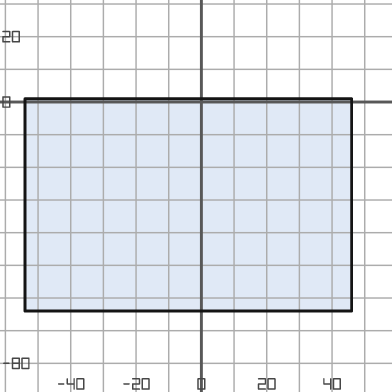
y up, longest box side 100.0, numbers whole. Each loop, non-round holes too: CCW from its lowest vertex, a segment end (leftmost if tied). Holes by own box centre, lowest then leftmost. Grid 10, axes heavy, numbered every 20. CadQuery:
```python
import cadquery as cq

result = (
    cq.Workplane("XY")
    .moveTo(-54.0, -64.0)
    .lineTo(46.0, -64.0)
    .lineTo(46.0, 1.0)
    .lineTo(-54.0, 1.0)
    .close()
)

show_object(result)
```